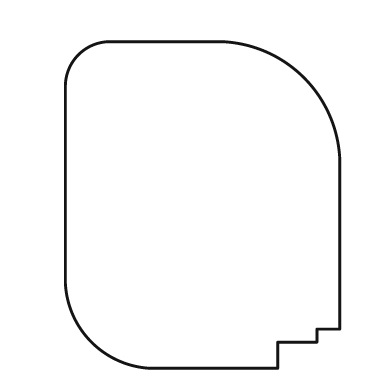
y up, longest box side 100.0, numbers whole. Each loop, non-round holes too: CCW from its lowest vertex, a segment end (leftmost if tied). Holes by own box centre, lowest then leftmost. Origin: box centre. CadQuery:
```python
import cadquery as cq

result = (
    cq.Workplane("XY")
    .moveTo(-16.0, -50.0)
    .lineTo(23.0, -50.0)
    .lineTo(23.0, -42.0)
    .lineTo(35.0, -42.0)
    .lineTo(35.0, -38.0)
    .lineTo(42.0, -38.0)
    .lineTo(42.0, 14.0)
    .threePointArc((31.0, 39.0), (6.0, 50.0))
    .lineTo(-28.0, 50.0)
    .threePointArc((-38.0, 46.0), (-42.0, 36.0))
    .lineTo(-42.0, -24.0)
    .threePointArc((-34.0, -42.0), (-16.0, -50.0))
    .close()
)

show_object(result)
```